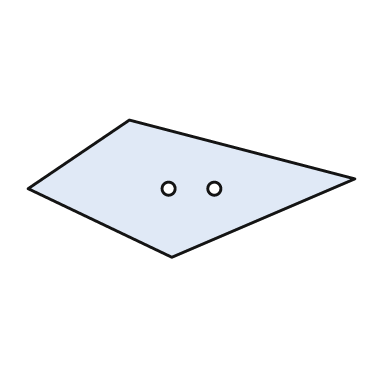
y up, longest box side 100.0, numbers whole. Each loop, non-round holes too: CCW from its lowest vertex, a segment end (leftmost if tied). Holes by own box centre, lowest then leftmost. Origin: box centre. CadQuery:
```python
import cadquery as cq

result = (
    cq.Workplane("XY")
    .moveTo(-6.0, -21.0)
    .lineTo(50.0, 3.0)
    .lineTo(-19.0, 21.0)
    .lineTo(-50.0, 0.0)
    .close()
    .moveTo(-7.0, 0.0)
    .circle(2.0)
    .moveTo(7.0, 0.0)
    .circle(2.0)
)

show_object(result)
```